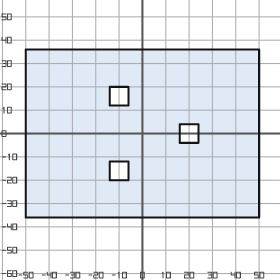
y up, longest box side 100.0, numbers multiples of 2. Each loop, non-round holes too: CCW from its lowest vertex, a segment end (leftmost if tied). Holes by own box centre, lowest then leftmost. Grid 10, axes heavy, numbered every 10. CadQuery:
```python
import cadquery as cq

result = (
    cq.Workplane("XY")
    .moveTo(-50.0, -36.0)
    .lineTo(50.0, -36.0)
    .lineTo(50.0, 36.0)
    .lineTo(-50.0, 36.0)
    .close()
    .moveTo(-14.0, -20.0)
    .lineTo(-6.0, -20.0)
    .lineTo(-6.0, -12.0)
    .lineTo(-14.0, -12.0)
    .close()
    .moveTo(16.0, -4.0)
    .lineTo(24.0, -4.0)
    .lineTo(24.0, 4.0)
    .lineTo(16.0, 4.0)
    .close()
    .moveTo(-14.0, 12.0)
    .lineTo(-6.0, 12.0)
    .lineTo(-6.0, 20.0)
    .lineTo(-14.0, 20.0)
    .close()
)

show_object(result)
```